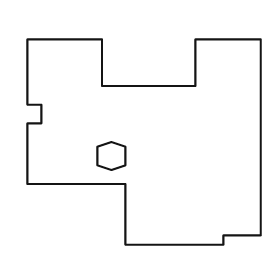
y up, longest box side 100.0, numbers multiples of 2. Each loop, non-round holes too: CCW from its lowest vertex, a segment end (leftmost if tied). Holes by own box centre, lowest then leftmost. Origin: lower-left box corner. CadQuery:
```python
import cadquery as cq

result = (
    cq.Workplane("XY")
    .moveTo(42.0, 0.0)
    .lineTo(84.0, 0.0)
    .lineTo(84.0, 4.0)
    .lineTo(100.0, 4.0)
    .lineTo(100.0, 88.0)
    .lineTo(72.0, 88.0)
    .lineTo(72.0, 68.0)
    .lineTo(32.0, 68.0)
    .lineTo(32.0, 88.0)
    .lineTo(0.0, 88.0)
    .lineTo(0.0, 60.0)
    .lineTo(6.0, 60.0)
    .lineTo(6.0, 52.0)
    .lineTo(0.0, 52.0)
    .lineTo(0.0, 26.0)
    .lineTo(42.0, 26.0)
    .close()
    .moveTo(36.0, 32.0)
    .lineTo(42.0, 34.0)
    .lineTo(42.0, 42.0)
    .lineTo(36.0, 44.0)
    .lineTo(30.0, 42.0)
    .lineTo(30.0, 34.0)
    .close()
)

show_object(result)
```